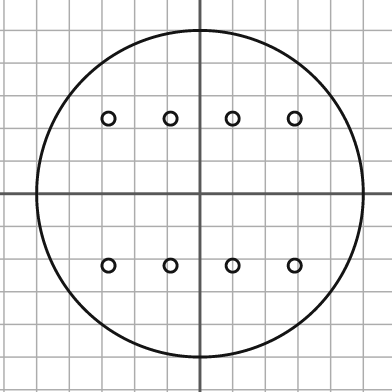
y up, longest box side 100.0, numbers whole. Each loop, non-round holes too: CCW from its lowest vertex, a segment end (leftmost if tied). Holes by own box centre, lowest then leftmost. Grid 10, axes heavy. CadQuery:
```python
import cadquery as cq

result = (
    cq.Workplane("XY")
    .moveTo(0.0, 0.0)
    .circle(50.0)
    .moveTo(-28.0, -22.0)
    .circle(2.0)
    .moveTo(-9.0, -22.0)
    .circle(2.0)
    .moveTo(10.0, -22.0)
    .circle(2.0)
    .moveTo(29.0, -22.0)
    .circle(2.0)
    .moveTo(-28.0, 23.0)
    .circle(2.0)
    .moveTo(-9.0, 23.0)
    .circle(2.0)
    .moveTo(10.0, 23.0)
    .circle(2.0)
    .moveTo(29.0, 23.0)
    .circle(2.0)
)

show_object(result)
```